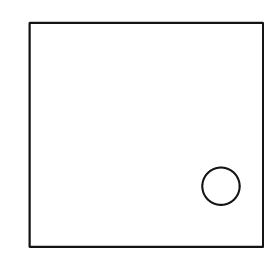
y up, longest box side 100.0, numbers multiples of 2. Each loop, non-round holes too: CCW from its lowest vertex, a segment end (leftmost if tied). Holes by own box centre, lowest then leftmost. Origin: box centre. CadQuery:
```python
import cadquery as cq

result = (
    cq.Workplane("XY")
    .moveTo(-50.0, -48.0)
    .lineTo(50.0, -48.0)
    .lineTo(50.0, 48.0)
    .lineTo(-50.0, 48.0)
    .close()
    .moveTo(32.0, -22.0)
    .circle(8.0)
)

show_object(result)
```